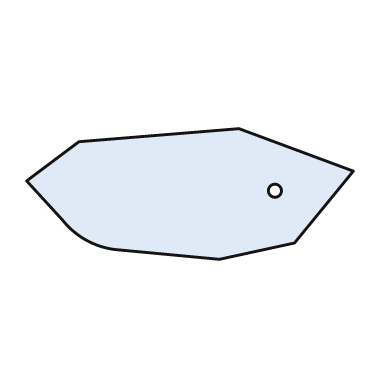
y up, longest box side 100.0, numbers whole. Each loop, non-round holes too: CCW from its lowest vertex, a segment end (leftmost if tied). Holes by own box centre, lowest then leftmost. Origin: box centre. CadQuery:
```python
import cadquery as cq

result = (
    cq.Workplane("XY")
    .moveTo(9.0, -20.0)
    .lineTo(32.0, -15.0)
    .lineTo(50.0, 7.0)
    .lineTo(15.0, 20.0)
    .lineTo(-34.0, 16.0)
    .lineTo(-50.0, 4.0)
    .lineTo(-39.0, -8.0)
    .threePointArc((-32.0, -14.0), (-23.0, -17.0))
    .close()
    .moveTo(26.0, 1.0)
    .circle(2.0)
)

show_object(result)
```